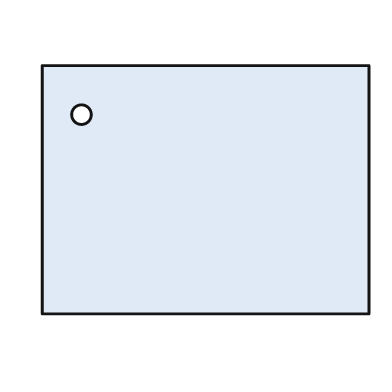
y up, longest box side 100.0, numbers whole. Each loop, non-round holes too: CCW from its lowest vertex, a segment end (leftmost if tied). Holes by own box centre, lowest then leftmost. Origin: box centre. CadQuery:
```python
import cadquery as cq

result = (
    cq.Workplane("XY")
    .moveTo(-50.0, -38.0)
    .lineTo(50.0, -38.0)
    .lineTo(50.0, 38.0)
    .lineTo(-50.0, 38.0)
    .close()
    .moveTo(-38.0, 23.0)
    .circle(3.0)
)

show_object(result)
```